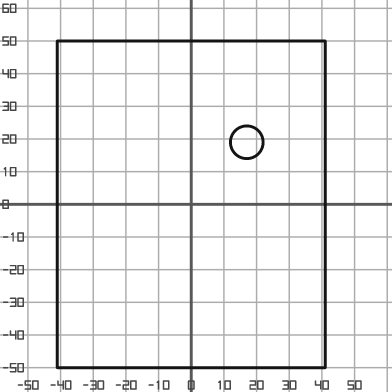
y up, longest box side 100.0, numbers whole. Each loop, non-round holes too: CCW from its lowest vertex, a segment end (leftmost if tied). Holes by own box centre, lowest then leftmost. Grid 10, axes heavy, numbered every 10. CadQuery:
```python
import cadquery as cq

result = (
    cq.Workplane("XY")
    .moveTo(-41.0, -50.0)
    .lineTo(41.0, -50.0)
    .lineTo(41.0, 50.0)
    .lineTo(-41.0, 50.0)
    .close()
    .moveTo(17.0, 19.0)
    .circle(5.0)
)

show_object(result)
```